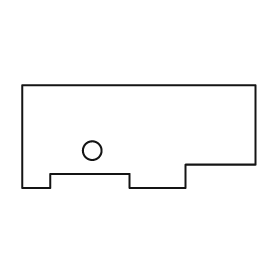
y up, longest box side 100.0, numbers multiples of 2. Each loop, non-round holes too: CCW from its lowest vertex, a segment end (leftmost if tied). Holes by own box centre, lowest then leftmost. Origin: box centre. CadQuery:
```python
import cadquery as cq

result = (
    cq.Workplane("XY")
    .moveTo(-50.0, -22.0)
    .lineTo(-38.0, -22.0)
    .lineTo(-38.0, -16.0)
    .lineTo(-4.0, -16.0)
    .lineTo(-4.0, -22.0)
    .lineTo(20.0, -22.0)
    .lineTo(20.0, -12.0)
    .lineTo(50.0, -12.0)
    .lineTo(50.0, 22.0)
    .lineTo(-50.0, 22.0)
    .close()
    .moveTo(-20.0, -6.0)
    .circle(4.0)
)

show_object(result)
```